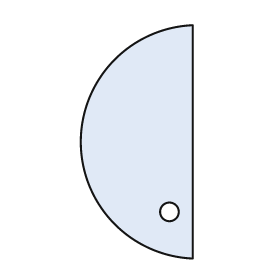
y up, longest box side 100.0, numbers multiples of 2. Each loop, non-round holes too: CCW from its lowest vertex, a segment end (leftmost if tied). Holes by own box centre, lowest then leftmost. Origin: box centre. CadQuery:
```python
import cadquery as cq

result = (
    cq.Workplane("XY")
    .moveTo(24.0, -50.0)
    .lineTo(24.0, 50.0)
    .threePointArc((-24.0, 0.0), (24.0, -50.0))
    .close()
    .moveTo(14.0, -30.0)
    .circle(4.0)
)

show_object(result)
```